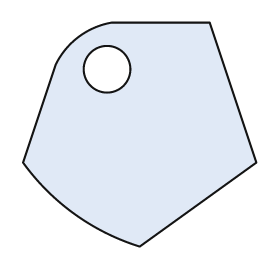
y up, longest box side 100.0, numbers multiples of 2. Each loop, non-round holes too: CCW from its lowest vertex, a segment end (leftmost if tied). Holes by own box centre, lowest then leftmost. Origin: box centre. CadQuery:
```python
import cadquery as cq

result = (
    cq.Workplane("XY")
    .moveTo(0.0, -48.0)
    .lineTo(50.0, -12.0)
    .lineTo(30.0, 48.0)
    .lineTo(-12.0, 48.0)
    .threePointArc((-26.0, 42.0), (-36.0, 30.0))
    .lineTo(-50.0, -12.0)
    .threePointArc((-28.0, -34.0), (0.0, -48.0))
    .close()
    .moveTo(-14.0, 28.0)
    .circle(10.0)
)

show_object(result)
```